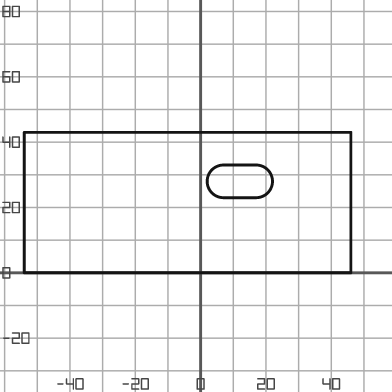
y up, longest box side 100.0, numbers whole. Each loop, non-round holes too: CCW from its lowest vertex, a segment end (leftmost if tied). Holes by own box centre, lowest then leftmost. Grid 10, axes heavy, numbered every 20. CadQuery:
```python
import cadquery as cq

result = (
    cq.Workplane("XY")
    .moveTo(-54.0, 0.0)
    .lineTo(46.0, 0.0)
    .lineTo(46.0, 43.0)
    .lineTo(-54.0, 43.0)
    .close()
    .moveTo(7.0, 23.0)
    .lineTo(17.0, 23.0)
    .threePointArc((22.0, 28.0), (17.0, 33.0))
    .lineTo(7.0, 33.0)
    .threePointArc((2.0, 28.0), (7.0, 23.0))
    .close()
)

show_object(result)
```